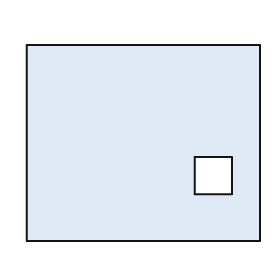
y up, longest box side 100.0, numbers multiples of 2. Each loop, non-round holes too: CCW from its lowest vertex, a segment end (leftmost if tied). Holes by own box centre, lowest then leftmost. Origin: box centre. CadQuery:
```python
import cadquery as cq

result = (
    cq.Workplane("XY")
    .moveTo(-50.0, -42.0)
    .lineTo(50.0, -42.0)
    .lineTo(50.0, 42.0)
    .lineTo(-50.0, 42.0)
    .close()
    .moveTo(22.0, -22.0)
    .lineTo(38.0, -22.0)
    .lineTo(38.0, -6.0)
    .lineTo(22.0, -6.0)
    .close()
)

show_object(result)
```